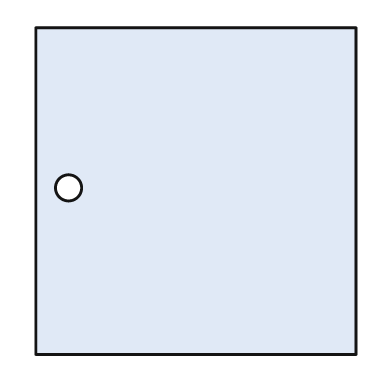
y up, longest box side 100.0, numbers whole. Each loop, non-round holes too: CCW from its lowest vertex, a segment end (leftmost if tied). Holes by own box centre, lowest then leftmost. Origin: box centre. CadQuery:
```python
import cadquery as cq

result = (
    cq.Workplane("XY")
    .moveTo(-49.0, -50.0)
    .lineTo(49.0, -50.0)
    .lineTo(49.0, 50.0)
    .lineTo(-49.0, 50.0)
    .close()
    .moveTo(-39.0, 1.0)
    .circle(4.0)
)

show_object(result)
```